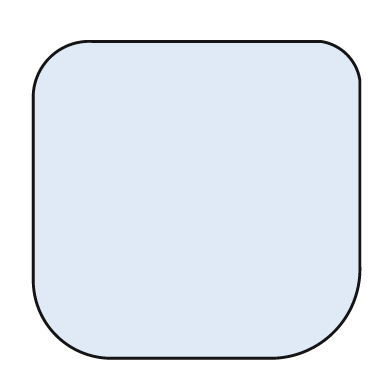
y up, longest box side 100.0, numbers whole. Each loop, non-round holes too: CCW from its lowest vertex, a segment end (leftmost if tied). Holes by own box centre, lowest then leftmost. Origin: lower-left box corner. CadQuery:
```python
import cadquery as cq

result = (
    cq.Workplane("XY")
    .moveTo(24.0, 0.0)
    .lineTo(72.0, 0.0)
    .threePointArc((92.0, 8.0), (100.0, 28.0))
    .lineTo(100.0, 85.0)
    .threePointArc((96.0, 93.0), (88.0, 97.0))
    .lineTo(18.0, 97.0)
    .threePointArc((5.0, 92.0), (0.0, 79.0))
    .lineTo(0.0, 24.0)
    .threePointArc((7.0, 7.0), (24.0, 0.0))
    .close()
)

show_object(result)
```